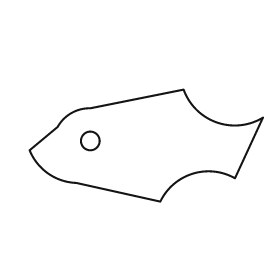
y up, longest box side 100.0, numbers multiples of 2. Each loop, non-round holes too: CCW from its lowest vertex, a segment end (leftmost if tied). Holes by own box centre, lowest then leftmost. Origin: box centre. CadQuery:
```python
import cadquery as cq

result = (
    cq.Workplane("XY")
    .moveTo(6.0, -24.0)
    .threePointArc((20.0, -12.0), (38.0, -14.0))
    .lineTo(50.0, 12.0)
    .threePointArc((30.0, 10.0), (16.0, 24.0))
    .lineTo(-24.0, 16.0)
    .threePointArc((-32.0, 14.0), (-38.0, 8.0))
    .lineTo(-50.0, -2.0)
    .threePointArc((-42.0, -12.0), (-30.0, -16.0))
    .close()
    .moveTo(-24.0, 2.0)
    .circle(4.0)
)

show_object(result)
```